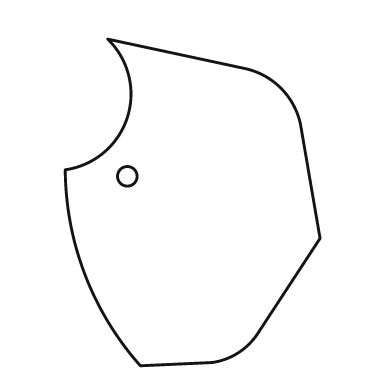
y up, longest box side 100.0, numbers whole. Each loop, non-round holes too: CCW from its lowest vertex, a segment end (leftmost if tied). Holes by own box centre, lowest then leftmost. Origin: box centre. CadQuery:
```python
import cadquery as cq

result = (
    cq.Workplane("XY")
    .moveTo(-16.0, -50.0)
    .lineTo(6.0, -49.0)
    .threePointArc((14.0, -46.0), (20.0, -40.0))
    .lineTo(39.0, -11.0)
    .lineTo(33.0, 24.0)
    .threePointArc((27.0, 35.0), (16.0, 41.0))
    .lineTo(-26.0, 50.0)
    .threePointArc((-20.0, 26.0), (-39.0, 10.0))
    .threePointArc((-33.0, -22.0), (-16.0, -50.0))
    .close()
    .moveTo(-20.0, 8.0)
    .circle(3.0)
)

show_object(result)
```